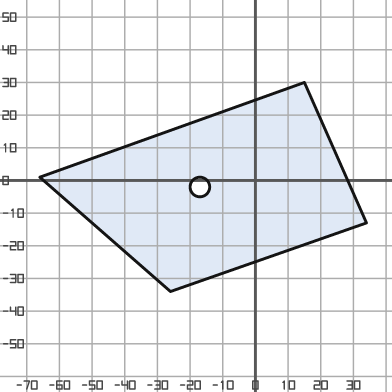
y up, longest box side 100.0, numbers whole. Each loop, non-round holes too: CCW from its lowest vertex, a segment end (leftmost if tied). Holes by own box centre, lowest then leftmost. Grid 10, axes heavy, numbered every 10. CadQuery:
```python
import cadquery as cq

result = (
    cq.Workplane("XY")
    .moveTo(-26.0, -34.0)
    .lineTo(34.0, -13.0)
    .lineTo(15.0, 30.0)
    .lineTo(-66.0, 1.0)
    .close()
    .moveTo(-17.0, -2.0)
    .circle(3.0)
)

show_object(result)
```